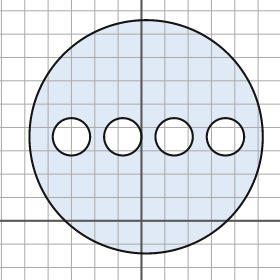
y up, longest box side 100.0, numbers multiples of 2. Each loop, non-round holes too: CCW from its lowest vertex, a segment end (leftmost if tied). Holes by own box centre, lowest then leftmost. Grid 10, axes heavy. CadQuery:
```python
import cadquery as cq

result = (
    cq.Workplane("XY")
    .moveTo(2.0, 36.0)
    .circle(50.0)
    .moveTo(-30.0, 36.0)
    .circle(8.0)
    .moveTo(-8.0, 36.0)
    .circle(8.0)
    .moveTo(14.0, 36.0)
    .circle(8.0)
    .moveTo(36.0, 36.0)
    .circle(8.0)
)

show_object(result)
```